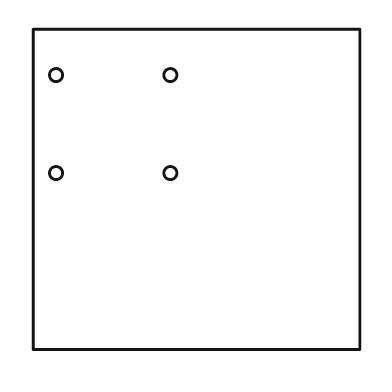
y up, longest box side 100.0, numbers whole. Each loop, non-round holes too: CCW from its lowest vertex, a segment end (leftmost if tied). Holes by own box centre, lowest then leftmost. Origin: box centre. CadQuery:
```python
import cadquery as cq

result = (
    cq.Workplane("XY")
    .moveTo(-50.0, -49.0)
    .lineTo(50.0, -49.0)
    .lineTo(50.0, 49.0)
    .lineTo(-50.0, 49.0)
    .close()
    .moveTo(-43.0, 5.0)
    .circle(2.0)
    .moveTo(-8.0, 5.0)
    .circle(2.0)
    .moveTo(-43.0, 35.0)
    .circle(2.0)
    .moveTo(-8.0, 35.0)
    .circle(2.0)
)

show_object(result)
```